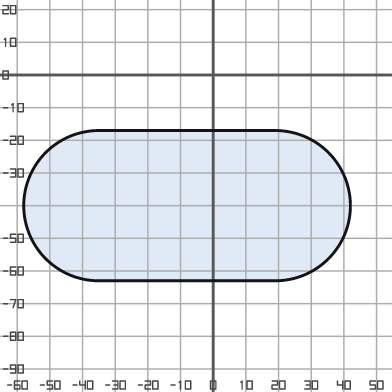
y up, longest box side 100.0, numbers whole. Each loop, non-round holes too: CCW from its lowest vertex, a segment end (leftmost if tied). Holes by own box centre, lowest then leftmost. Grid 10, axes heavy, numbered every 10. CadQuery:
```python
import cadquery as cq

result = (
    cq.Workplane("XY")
    .moveTo(-35.0, -63.0)
    .lineTo(19.0, -63.0)
    .threePointArc((42.0, -40.0), (19.0, -17.0))
    .lineTo(-35.0, -17.0)
    .threePointArc((-58.0, -40.0), (-35.0, -63.0))
    .close()
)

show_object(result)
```